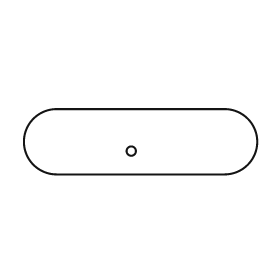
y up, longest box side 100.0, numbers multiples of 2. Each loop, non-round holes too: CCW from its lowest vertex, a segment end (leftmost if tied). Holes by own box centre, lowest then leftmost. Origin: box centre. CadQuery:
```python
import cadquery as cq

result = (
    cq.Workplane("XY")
    .moveTo(-36.0, -14.0)
    .lineTo(36.0, -14.0)
    .threePointArc((50.0, 0.0), (36.0, 14.0))
    .lineTo(-36.0, 14.0)
    .threePointArc((-50.0, 0.0), (-36.0, -14.0))
    .close()
    .moveTo(-4.0, -4.0)
    .circle(2.0)
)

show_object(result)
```